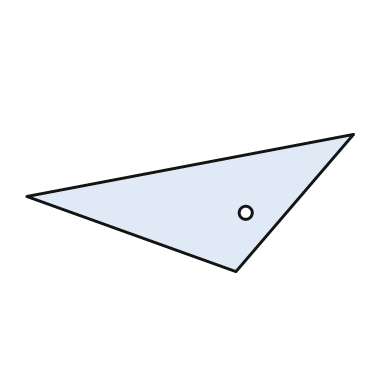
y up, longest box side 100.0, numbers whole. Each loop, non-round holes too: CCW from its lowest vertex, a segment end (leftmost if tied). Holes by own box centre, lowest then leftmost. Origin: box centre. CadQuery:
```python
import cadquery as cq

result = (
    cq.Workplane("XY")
    .moveTo(14.0, -21.0)
    .lineTo(50.0, 21.0)
    .lineTo(-50.0, 2.0)
    .close()
    .moveTo(17.0, -3.0)
    .circle(2.0)
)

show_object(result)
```